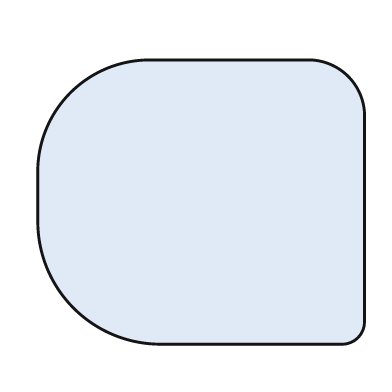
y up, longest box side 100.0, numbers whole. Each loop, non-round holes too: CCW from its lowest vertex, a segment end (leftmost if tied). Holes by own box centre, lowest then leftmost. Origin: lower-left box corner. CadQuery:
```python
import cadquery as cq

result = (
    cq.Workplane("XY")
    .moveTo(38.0, 0.0)
    .lineTo(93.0, 0.0)
    .threePointArc((98.0, 2.0), (100.0, 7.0))
    .lineTo(100.0, 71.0)
    .threePointArc((95.0, 82.0), (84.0, 87.0))
    .lineTo(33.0, 87.0)
    .threePointArc((10.0, 77.0), (0.0, 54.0))
    .lineTo(0.0, 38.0)
    .threePointArc((11.0, 11.0), (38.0, 0.0))
    .close()
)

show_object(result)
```